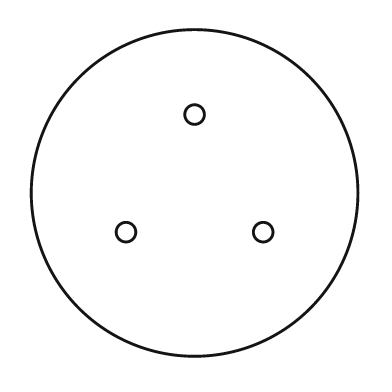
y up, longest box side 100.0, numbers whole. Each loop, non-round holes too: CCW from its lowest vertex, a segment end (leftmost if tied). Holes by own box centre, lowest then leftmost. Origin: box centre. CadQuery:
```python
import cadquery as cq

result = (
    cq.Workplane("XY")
    .moveTo(0.0, 0.0)
    .circle(50.0)
    .moveTo(-21.0, -12.0)
    .circle(3.0)
    .moveTo(21.0, -12.0)
    .circle(3.0)
    .moveTo(0.0, 24.0)
    .circle(3.0)
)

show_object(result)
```